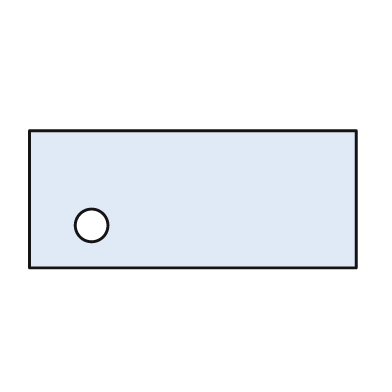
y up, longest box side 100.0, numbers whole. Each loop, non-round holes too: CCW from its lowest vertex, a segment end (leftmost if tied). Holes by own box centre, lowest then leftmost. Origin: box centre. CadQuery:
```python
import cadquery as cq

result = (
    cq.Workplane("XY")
    .moveTo(-50.0, -21.0)
    .lineTo(50.0, -21.0)
    .lineTo(50.0, 21.0)
    .lineTo(-50.0, 21.0)
    .close()
    .moveTo(-31.0, -8.0)
    .circle(5.0)
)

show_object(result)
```